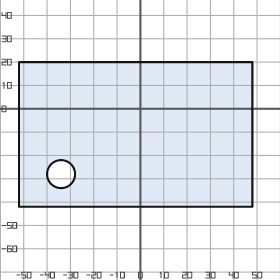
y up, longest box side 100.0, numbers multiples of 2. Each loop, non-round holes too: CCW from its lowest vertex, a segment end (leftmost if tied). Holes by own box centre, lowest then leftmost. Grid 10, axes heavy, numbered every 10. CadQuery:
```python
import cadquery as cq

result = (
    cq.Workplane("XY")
    .moveTo(-52.0, -42.0)
    .lineTo(48.0, -42.0)
    .lineTo(48.0, 20.0)
    .lineTo(-52.0, 20.0)
    .close()
    .moveTo(-34.0, -28.0)
    .circle(6.0)
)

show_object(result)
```